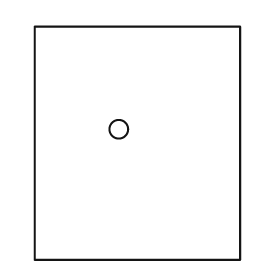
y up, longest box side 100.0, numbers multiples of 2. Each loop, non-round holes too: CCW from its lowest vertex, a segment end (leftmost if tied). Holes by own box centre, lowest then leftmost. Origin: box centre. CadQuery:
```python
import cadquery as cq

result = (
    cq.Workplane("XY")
    .moveTo(-44.0, -50.0)
    .lineTo(44.0, -50.0)
    .lineTo(44.0, 50.0)
    .lineTo(-44.0, 50.0)
    .close()
    .moveTo(-8.0, 6.0)
    .circle(4.0)
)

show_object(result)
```